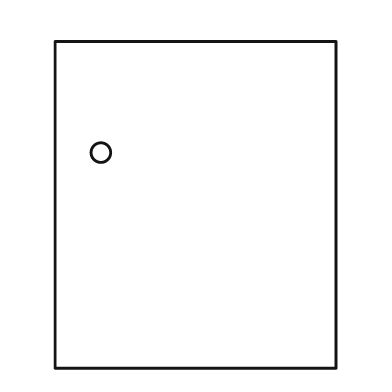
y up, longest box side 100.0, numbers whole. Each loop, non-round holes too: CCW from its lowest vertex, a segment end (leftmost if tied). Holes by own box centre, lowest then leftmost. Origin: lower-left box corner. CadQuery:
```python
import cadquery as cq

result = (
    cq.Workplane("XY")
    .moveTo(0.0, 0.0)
    .lineTo(86.0, 0.0)
    .lineTo(86.0, 100.0)
    .lineTo(0.0, 100.0)
    .close()
    .moveTo(14.0, 66.0)
    .circle(3.0)
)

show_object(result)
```